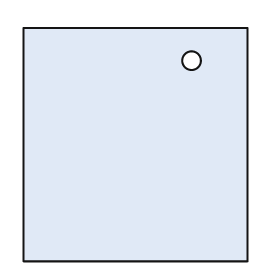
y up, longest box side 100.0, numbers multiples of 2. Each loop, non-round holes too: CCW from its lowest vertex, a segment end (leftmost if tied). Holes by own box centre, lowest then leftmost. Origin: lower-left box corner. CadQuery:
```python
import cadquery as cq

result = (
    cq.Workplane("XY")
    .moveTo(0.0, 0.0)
    .lineTo(96.0, 0.0)
    .lineTo(96.0, 100.0)
    .lineTo(0.0, 100.0)
    .close()
    .moveTo(72.0, 86.0)
    .circle(4.0)
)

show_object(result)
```